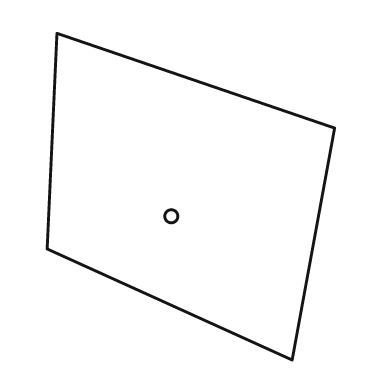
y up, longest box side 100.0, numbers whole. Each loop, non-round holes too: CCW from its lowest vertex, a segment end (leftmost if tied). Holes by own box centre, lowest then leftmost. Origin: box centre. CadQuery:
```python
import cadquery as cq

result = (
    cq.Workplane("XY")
    .moveTo(31.0, -50.0)
    .lineTo(44.0, 21.0)
    .lineTo(-41.0, 50.0)
    .lineTo(-44.0, -16.0)
    .close()
    .moveTo(-6.0, -6.0)
    .circle(2.0)
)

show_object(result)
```